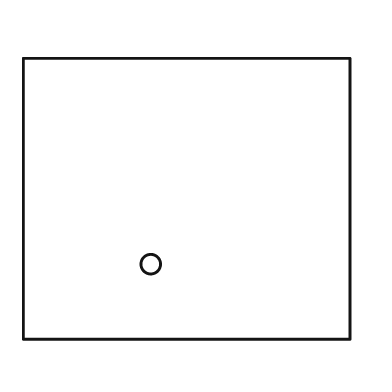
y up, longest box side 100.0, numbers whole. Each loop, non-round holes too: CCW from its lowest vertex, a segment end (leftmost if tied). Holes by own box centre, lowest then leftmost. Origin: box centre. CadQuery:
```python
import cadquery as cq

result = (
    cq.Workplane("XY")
    .moveTo(-50.0, -43.0)
    .lineTo(50.0, -43.0)
    .lineTo(50.0, 43.0)
    .lineTo(-50.0, 43.0)
    .close()
    .moveTo(-11.0, -20.0)
    .circle(3.0)
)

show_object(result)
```